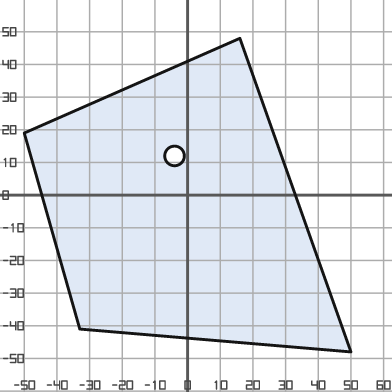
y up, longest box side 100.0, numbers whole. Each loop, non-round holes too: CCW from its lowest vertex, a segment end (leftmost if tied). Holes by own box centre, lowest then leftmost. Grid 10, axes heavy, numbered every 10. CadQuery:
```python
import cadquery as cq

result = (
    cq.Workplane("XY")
    .moveTo(50.0, -48.0)
    .lineTo(16.0, 48.0)
    .lineTo(-50.0, 19.0)
    .lineTo(-33.0, -41.0)
    .close()
    .moveTo(-4.0, 12.0)
    .circle(3.0)
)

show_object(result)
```